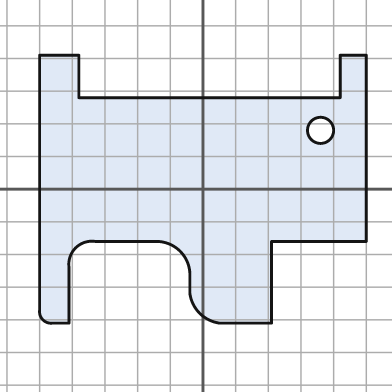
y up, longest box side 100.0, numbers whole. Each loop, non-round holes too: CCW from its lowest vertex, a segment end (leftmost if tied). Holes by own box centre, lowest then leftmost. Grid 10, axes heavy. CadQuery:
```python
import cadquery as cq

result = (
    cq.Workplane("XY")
    .moveTo(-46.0, -41.0)
    .lineTo(-41.0, -41.0)
    .lineTo(-41.0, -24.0)
    .threePointArc((-39.0, -18.0), (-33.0, -16.0))
    .lineTo(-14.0, -16.0)
    .threePointArc((-7.0, -19.0), (-4.0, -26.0))
    .lineTo(-4.0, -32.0)
    .threePointArc((-1.0, -38.0), (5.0, -41.0))
    .lineTo(21.0, -41.0)
    .lineTo(21.0, -16.0)
    .lineTo(50.0, -16.0)
    .lineTo(50.0, 41.0)
    .lineTo(42.0, 41.0)
    .lineTo(42.0, 28.0)
    .lineTo(-38.0, 28.0)
    .lineTo(-38.0, 41.0)
    .lineTo(-50.0, 41.0)
    .lineTo(-50.0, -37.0)
    .threePointArc((-49.0, -40.0), (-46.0, -41.0))
    .close()
    .moveTo(36.0, 18.0)
    .circle(4.0)
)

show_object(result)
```